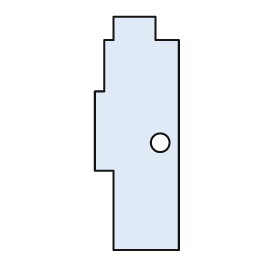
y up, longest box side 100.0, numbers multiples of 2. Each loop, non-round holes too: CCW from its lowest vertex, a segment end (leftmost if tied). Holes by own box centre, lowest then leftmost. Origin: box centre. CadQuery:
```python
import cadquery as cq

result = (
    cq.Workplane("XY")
    .moveTo(-10.0, -50.0)
    .lineTo(18.0, -50.0)
    .lineTo(18.0, 40.0)
    .lineTo(8.0, 40.0)
    .lineTo(8.0, 50.0)
    .lineTo(-10.0, 50.0)
    .lineTo(-10.0, 40.0)
    .lineTo(-14.0, 40.0)
    .lineTo(-14.0, 18.0)
    .lineTo(-18.0, 18.0)
    .lineTo(-18.0, -16.0)
    .lineTo(-10.0, -16.0)
    .close()
    .moveTo(10.0, -4.0)
    .circle(4.0)
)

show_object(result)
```